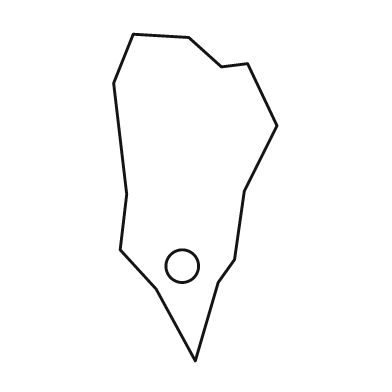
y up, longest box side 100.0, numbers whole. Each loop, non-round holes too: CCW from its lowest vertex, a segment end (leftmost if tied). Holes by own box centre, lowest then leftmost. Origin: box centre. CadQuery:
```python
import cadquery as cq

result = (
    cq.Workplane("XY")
    .moveTo(0.0, -50.0)
    .lineTo(7.0, -26.0)
    .lineTo(12.0, -19.0)
    .lineTo(15.0, 2.0)
    .lineTo(25.0, 22.0)
    .lineTo(16.0, 41.0)
    .lineTo(8.0, 40.0)
    .lineTo(-2.0, 49.0)
    .lineTo(-19.0, 50.0)
    .lineTo(-25.0, 35.0)
    .lineTo(-21.0, 1.0)
    .lineTo(-23.0, -16.0)
    .lineTo(-12.0, -28.0)
    .close()
    .moveTo(-4.0, -21.0)
    .circle(5.0)
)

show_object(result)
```